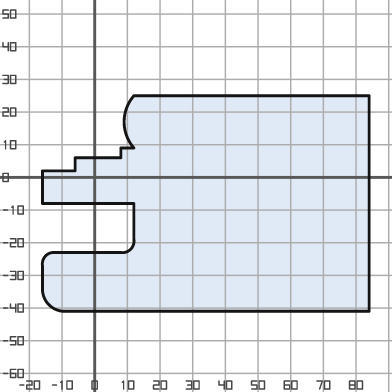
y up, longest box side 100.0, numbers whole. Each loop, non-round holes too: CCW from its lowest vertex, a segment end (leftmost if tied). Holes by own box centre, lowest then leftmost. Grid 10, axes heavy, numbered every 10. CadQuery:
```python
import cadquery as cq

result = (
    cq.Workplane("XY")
    .moveTo(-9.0, -41.0)
    .lineTo(84.0, -41.0)
    .lineTo(84.0, 25.0)
    .lineTo(12.0, 25.0)
    .threePointArc((9.0, 17.0), (12.0, 9.0))
    .lineTo(8.0, 9.0)
    .lineTo(8.0, 6.0)
    .lineTo(-6.0, 6.0)
    .lineTo(-6.0, 2.0)
    .lineTo(-16.0, 2.0)
    .lineTo(-16.0, -8.0)
    .lineTo(12.0, -8.0)
    .lineTo(12.0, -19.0)
    .threePointArc((11.0, -22.0), (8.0, -23.0))
    .lineTo(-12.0, -23.0)
    .threePointArc((-15.0, -24.0), (-16.0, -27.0))
    .lineTo(-16.0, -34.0)
    .threePointArc((-14.0, -39.0), (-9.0, -41.0))
    .close()
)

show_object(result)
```